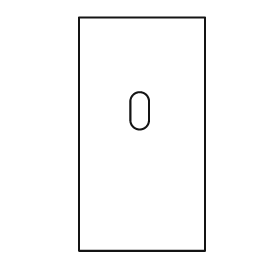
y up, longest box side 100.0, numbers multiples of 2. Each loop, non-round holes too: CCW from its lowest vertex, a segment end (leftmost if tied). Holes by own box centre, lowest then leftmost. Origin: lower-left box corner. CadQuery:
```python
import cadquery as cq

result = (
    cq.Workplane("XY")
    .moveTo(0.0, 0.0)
    .lineTo(54.0, 0.0)
    .lineTo(54.0, 100.0)
    .lineTo(0.0, 100.0)
    .close()
    .moveTo(22.0, 56.0)
    .threePointArc((26.0, 52.0), (30.0, 56.0))
    .lineTo(30.0, 64.0)
    .threePointArc((26.0, 68.0), (22.0, 64.0))
    .close()
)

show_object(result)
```